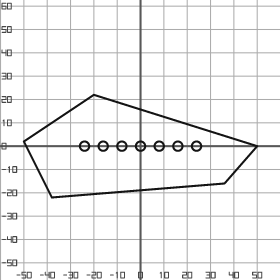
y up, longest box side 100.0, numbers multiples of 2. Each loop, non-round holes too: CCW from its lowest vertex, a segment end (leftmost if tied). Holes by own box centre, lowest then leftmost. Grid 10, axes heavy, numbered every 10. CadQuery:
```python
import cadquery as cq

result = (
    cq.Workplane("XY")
    .moveTo(-38.0, -22.0)
    .lineTo(36.0, -16.0)
    .lineTo(50.0, 0.0)
    .lineTo(-20.0, 22.0)
    .lineTo(-50.0, 2.0)
    .close()
    .moveTo(-24.0, 0.0)
    .circle(2.0)
    .moveTo(-16.0, 0.0)
    .circle(2.0)
    .moveTo(-8.0, 0.0)
    .circle(2.0)
    .moveTo(0.0, 0.0)
    .circle(2.0)
    .moveTo(8.0, 0.0)
    .circle(2.0)
    .moveTo(16.0, 0.0)
    .circle(2.0)
    .moveTo(24.0, 0.0)
    .circle(2.0)
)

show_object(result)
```